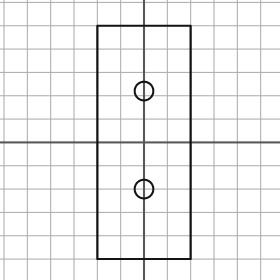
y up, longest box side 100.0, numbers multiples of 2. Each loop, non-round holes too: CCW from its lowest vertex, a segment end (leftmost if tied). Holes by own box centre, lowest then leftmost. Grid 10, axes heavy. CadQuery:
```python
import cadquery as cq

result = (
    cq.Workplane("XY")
    .moveTo(-20.0, -50.0)
    .lineTo(20.0, -50.0)
    .lineTo(20.0, 50.0)
    .lineTo(-20.0, 50.0)
    .close()
    .moveTo(0.0, -20.0)
    .circle(4.0)
    .moveTo(0.0, 22.0)
    .circle(4.0)
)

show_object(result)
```